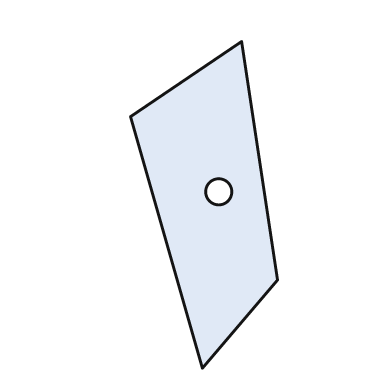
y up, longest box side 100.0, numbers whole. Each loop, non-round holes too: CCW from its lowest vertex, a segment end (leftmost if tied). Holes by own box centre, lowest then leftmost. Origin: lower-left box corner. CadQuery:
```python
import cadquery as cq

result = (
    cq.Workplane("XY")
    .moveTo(22.0, 0.0)
    .lineTo(45.0, 27.0)
    .lineTo(34.0, 100.0)
    .lineTo(0.0, 77.0)
    .close()
    .moveTo(27.0, 54.0)
    .circle(4.0)
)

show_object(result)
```